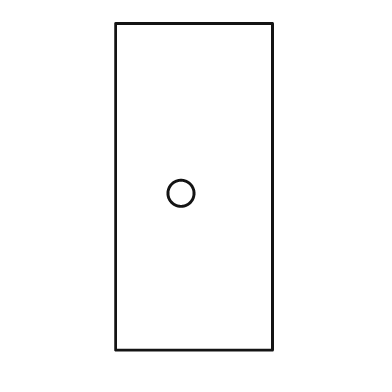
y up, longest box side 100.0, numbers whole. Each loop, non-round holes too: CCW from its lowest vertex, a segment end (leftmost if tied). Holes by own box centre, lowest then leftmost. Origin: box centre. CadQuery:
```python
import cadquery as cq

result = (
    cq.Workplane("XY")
    .moveTo(-24.0, -50.0)
    .lineTo(24.0, -50.0)
    .lineTo(24.0, 50.0)
    .lineTo(-24.0, 50.0)
    .close()
    .moveTo(-4.0, -2.0)
    .circle(4.0)
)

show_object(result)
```